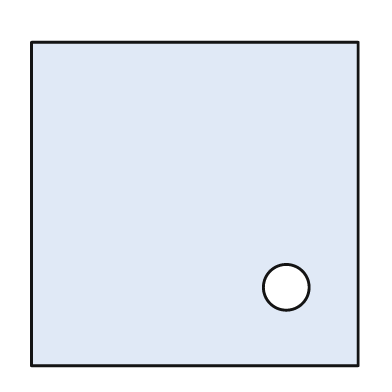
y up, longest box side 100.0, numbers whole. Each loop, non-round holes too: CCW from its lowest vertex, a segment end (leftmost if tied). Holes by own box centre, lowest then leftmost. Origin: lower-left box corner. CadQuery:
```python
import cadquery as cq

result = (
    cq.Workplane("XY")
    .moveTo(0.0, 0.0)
    .lineTo(100.0, 0.0)
    .lineTo(100.0, 99.0)
    .lineTo(0.0, 99.0)
    .close()
    .moveTo(78.0, 24.0)
    .circle(7.0)
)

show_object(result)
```